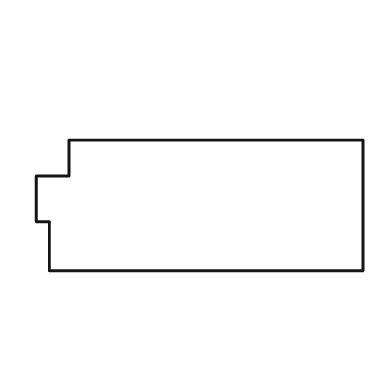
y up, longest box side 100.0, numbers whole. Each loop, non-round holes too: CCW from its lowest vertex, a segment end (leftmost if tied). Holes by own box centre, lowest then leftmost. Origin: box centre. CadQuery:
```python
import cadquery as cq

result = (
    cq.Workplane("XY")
    .moveTo(-46.0, -20.0)
    .lineTo(50.0, -20.0)
    .lineTo(50.0, 20.0)
    .lineTo(-40.0, 20.0)
    .lineTo(-40.0, 9.0)
    .lineTo(-50.0, 9.0)
    .lineTo(-50.0, -5.0)
    .lineTo(-46.0, -5.0)
    .close()
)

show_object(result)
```